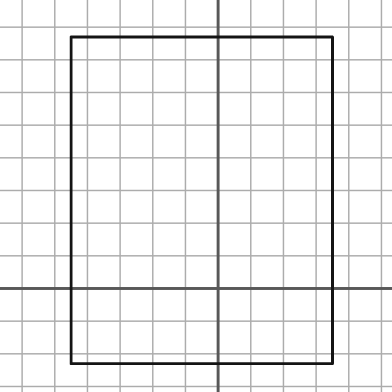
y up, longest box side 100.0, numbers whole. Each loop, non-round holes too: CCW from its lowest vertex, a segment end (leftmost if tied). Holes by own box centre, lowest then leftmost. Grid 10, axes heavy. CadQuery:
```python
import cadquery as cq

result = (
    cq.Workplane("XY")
    .moveTo(-45.0, -23.0)
    .lineTo(35.0, -23.0)
    .lineTo(35.0, 77.0)
    .lineTo(-45.0, 77.0)
    .close()
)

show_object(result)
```